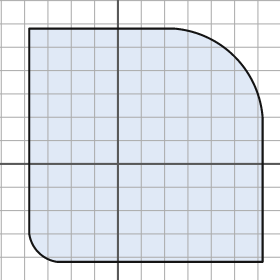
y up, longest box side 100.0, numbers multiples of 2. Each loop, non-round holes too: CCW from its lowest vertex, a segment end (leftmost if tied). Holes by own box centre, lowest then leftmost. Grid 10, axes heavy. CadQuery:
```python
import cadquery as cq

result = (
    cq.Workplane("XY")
    .moveTo(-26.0, -42.0)
    .lineTo(62.0, -42.0)
    .lineTo(62.0, 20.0)
    .threePointArc((50.0, 46.0), (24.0, 58.0))
    .lineTo(-38.0, 58.0)
    .lineTo(-38.0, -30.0)
    .threePointArc((-34.0, -38.0), (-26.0, -42.0))
    .close()
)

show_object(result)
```